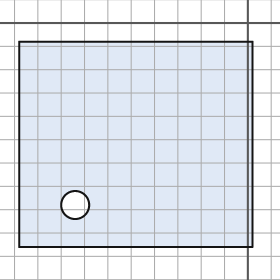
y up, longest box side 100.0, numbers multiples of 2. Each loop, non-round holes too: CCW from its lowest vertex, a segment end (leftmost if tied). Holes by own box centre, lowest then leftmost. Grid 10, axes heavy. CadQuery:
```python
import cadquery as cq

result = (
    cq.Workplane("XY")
    .moveTo(-98.0, -96.0)
    .lineTo(2.0, -96.0)
    .lineTo(2.0, -8.0)
    .lineTo(-98.0, -8.0)
    .close()
    .moveTo(-74.0, -78.0)
    .circle(6.0)
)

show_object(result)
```